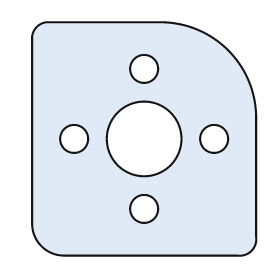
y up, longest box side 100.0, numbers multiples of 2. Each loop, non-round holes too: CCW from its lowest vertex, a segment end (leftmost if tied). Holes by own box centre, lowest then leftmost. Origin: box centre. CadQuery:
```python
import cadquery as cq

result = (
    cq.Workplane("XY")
    .moveTo(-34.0, -50.0)
    .lineTo(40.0, -50.0)
    .threePointArc((46.0, -48.0), (48.0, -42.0))
    .lineTo(48.0, 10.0)
    .threePointArc((36.0, 38.0), (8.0, 50.0))
    .lineTo(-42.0, 50.0)
    .threePointArc((-46.0, 48.0), (-48.0, 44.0))
    .lineTo(-48.0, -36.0)
    .threePointArc((-44.0, -46.0), (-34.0, -50.0))
    .close()
    .moveTo(0.0, -30.0)
    .circle(6.0)
    .moveTo(-30.0, 0.0)
    .circle(6.0)
    .moveTo(0.0, 0.0)
    .circle(16.0)
    .moveTo(30.0, 0.0)
    .circle(6.0)
    .moveTo(0.0, 30.0)
    .circle(6.0)
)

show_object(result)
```